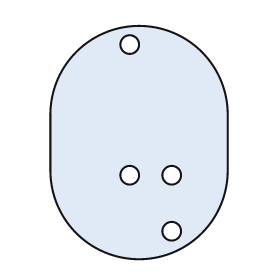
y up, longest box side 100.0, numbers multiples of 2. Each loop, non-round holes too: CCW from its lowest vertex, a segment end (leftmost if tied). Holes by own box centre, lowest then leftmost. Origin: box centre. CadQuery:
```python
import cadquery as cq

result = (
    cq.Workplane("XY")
    .moveTo(-38.0, -12.0)
    .threePointArc((0.0, -50.0), (38.0, -12.0))
    .lineTo(38.0, 12.0)
    .threePointArc((0.0, 50.0), (-38.0, 12.0))
    .close()
    .moveTo(14.0, -38.0)
    .circle(4.0)
    .moveTo(-4.0, -14.0)
    .circle(4.0)
    .moveTo(14.0, -14.0)
    .circle(4.0)
    .moveTo(-4.0, 42.0)
    .circle(4.0)
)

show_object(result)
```